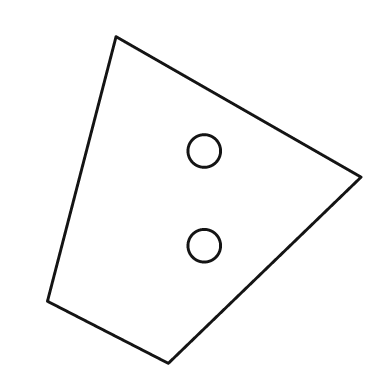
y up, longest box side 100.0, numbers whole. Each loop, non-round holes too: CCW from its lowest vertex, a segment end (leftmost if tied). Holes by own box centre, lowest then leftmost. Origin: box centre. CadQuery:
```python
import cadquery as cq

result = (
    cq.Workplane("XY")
    .moveTo(-11.0, -50.0)
    .lineTo(48.0, 7.0)
    .lineTo(-27.0, 50.0)
    .lineTo(-48.0, -31.0)
    .close()
    .moveTo(0.0, -14.0)
    .circle(5.0)
    .moveTo(0.0, 15.0)
    .circle(5.0)
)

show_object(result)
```